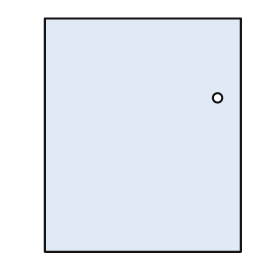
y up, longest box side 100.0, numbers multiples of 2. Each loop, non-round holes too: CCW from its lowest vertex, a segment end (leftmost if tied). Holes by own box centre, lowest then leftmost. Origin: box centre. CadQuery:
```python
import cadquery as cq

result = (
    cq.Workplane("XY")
    .moveTo(-42.0, -50.0)
    .lineTo(42.0, -50.0)
    .lineTo(42.0, 50.0)
    .lineTo(-42.0, 50.0)
    .close()
    .moveTo(32.0, 16.0)
    .circle(2.0)
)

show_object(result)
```